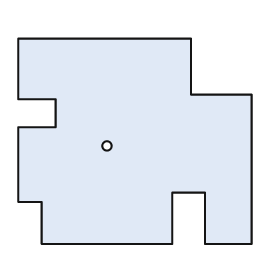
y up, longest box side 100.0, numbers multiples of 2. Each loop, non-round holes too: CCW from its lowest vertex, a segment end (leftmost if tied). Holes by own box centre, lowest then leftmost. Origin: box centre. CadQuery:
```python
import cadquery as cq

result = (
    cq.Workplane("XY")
    .moveTo(-40.0, -44.0)
    .lineTo(16.0, -44.0)
    .lineTo(16.0, -22.0)
    .lineTo(30.0, -22.0)
    .lineTo(30.0, -44.0)
    .lineTo(50.0, -44.0)
    .lineTo(50.0, 20.0)
    .lineTo(24.0, 20.0)
    .lineTo(24.0, 44.0)
    .lineTo(-50.0, 44.0)
    .lineTo(-50.0, 18.0)
    .lineTo(-34.0, 18.0)
    .lineTo(-34.0, 6.0)
    .lineTo(-50.0, 6.0)
    .lineTo(-50.0, -26.0)
    .lineTo(-40.0, -26.0)
    .close()
    .moveTo(-12.0, -2.0)
    .circle(2.0)
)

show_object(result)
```